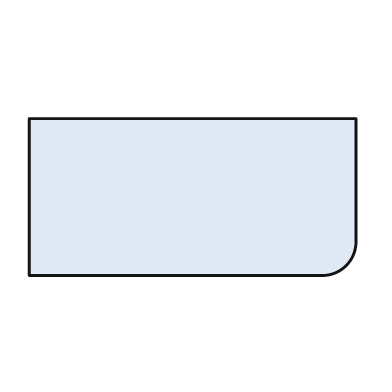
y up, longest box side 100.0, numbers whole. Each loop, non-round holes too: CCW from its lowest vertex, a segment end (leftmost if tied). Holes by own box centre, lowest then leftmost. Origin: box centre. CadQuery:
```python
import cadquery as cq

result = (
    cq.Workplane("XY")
    .moveTo(-50.0, -24.0)
    .lineTo(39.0, -24.0)
    .threePointArc((47.0, -21.0), (50.0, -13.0))
    .lineTo(50.0, 24.0)
    .lineTo(-50.0, 24.0)
    .close()
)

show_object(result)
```